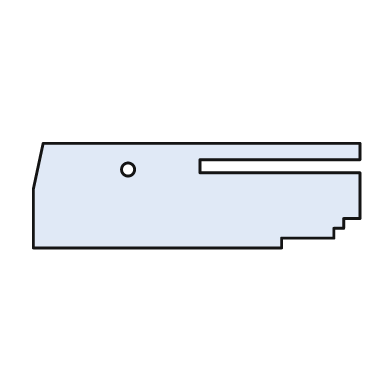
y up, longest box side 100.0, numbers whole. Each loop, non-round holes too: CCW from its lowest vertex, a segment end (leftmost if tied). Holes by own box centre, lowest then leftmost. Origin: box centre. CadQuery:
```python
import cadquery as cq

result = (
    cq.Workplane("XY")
    .moveTo(-50.0, -16.0)
    .lineTo(26.0, -16.0)
    .lineTo(26.0, -13.0)
    .lineTo(42.0, -13.0)
    .lineTo(42.0, -10.0)
    .lineTo(45.0, -10.0)
    .lineTo(45.0, -7.0)
    .lineTo(50.0, -7.0)
    .lineTo(50.0, 7.0)
    .lineTo(1.0, 7.0)
    .lineTo(1.0, 11.0)
    .lineTo(50.0, 11.0)
    .lineTo(50.0, 16.0)
    .lineTo(-47.0, 16.0)
    .lineTo(-50.0, 2.0)
    .close()
    .moveTo(-21.0, 8.0)
    .circle(2.0)
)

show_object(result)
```